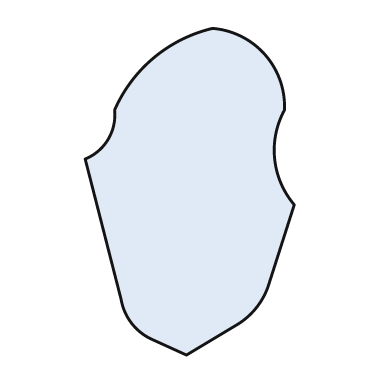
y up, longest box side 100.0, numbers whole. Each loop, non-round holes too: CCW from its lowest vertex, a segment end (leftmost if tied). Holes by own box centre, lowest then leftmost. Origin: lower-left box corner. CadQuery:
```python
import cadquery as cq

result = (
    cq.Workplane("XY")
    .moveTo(31.0, 0.0)
    .lineTo(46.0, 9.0)
    .threePointArc((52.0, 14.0), (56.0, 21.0))
    .lineTo(64.0, 46.0)
    .threePointArc((58.0, 60.0), (61.0, 75.0))
    .threePointArc((55.0, 92.0), (39.0, 100.0))
    .threePointArc((21.0, 91.0), (9.0, 75.0))
    .threePointArc((7.0, 66.0), (0.0, 60.0))
    .lineTo(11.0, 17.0)
    .threePointArc((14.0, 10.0), (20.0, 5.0))
    .close()
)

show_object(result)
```